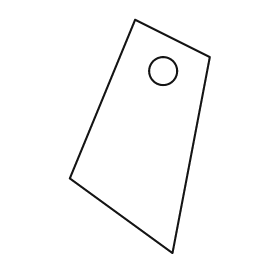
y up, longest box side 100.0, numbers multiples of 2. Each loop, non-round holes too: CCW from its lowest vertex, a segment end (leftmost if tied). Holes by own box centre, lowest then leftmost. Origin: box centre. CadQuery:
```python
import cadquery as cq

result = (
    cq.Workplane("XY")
    .moveTo(14.0, -50.0)
    .lineTo(30.0, 34.0)
    .lineTo(-2.0, 50.0)
    .lineTo(-30.0, -18.0)
    .close()
    .moveTo(10.0, 28.0)
    .circle(6.0)
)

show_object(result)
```